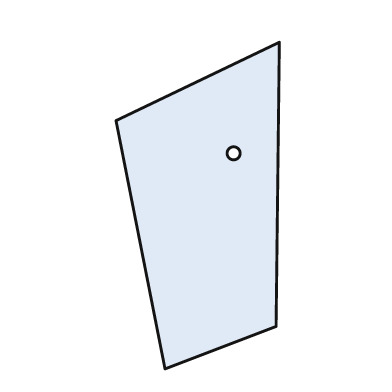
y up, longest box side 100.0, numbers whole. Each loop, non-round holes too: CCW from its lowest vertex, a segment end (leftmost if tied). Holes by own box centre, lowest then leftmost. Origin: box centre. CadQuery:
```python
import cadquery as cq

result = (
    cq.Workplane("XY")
    .moveTo(-10.0, -50.0)
    .lineTo(24.0, -37.0)
    .lineTo(25.0, 50.0)
    .lineTo(-25.0, 26.0)
    .close()
    .moveTo(11.0, 16.0)
    .circle(2.0)
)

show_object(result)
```